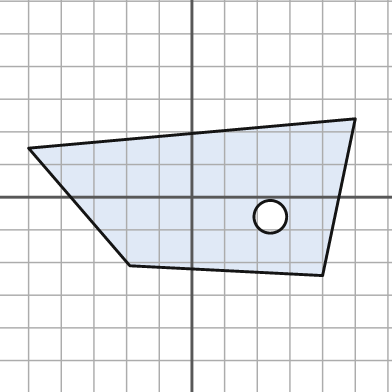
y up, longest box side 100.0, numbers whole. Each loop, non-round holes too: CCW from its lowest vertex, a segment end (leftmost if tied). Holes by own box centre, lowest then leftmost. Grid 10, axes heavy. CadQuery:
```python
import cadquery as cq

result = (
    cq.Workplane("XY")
    .moveTo(40.0, -24.0)
    .lineTo(50.0, 24.0)
    .lineTo(-50.0, 15.0)
    .lineTo(-19.0, -21.0)
    .close()
    .moveTo(24.0, -6.0)
    .circle(5.0)
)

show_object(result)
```